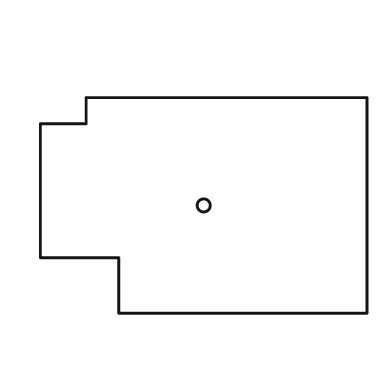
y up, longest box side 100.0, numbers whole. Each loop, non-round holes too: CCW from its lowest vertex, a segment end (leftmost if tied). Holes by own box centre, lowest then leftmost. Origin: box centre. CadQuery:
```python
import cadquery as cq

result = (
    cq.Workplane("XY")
    .moveTo(-26.0, -33.0)
    .lineTo(50.0, -33.0)
    .lineTo(50.0, 33.0)
    .lineTo(-36.0, 33.0)
    .lineTo(-36.0, 25.0)
    .lineTo(-50.0, 25.0)
    .lineTo(-50.0, -16.0)
    .lineTo(-26.0, -16.0)
    .close()
    .moveTo(0.0, 0.0)
    .circle(2.0)
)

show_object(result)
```